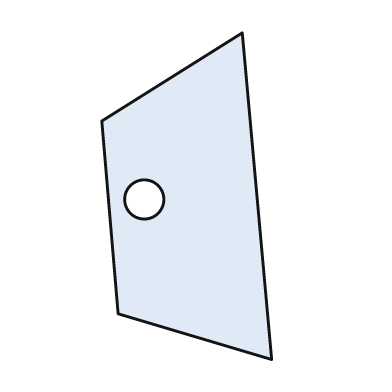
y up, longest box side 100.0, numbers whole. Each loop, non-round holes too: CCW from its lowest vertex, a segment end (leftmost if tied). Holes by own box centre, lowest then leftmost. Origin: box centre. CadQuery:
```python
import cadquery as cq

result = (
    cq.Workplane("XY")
    .moveTo(26.0, -50.0)
    .lineTo(17.0, 50.0)
    .lineTo(-26.0, 23.0)
    .lineTo(-21.0, -36.0)
    .close()
    .moveTo(-13.0, -1.0)
    .circle(6.0)
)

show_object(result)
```